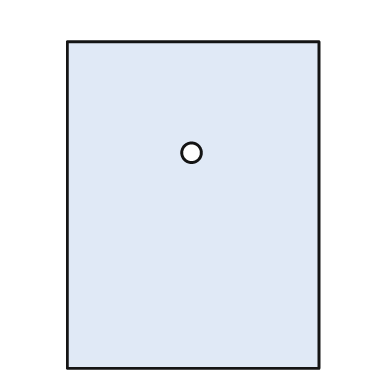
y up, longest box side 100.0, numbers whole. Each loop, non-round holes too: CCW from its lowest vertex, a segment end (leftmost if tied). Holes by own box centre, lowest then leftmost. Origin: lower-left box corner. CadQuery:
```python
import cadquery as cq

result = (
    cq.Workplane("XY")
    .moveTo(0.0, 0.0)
    .lineTo(77.0, 0.0)
    .lineTo(77.0, 100.0)
    .lineTo(0.0, 100.0)
    .close()
    .moveTo(38.0, 66.0)
    .circle(3.0)
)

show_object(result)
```